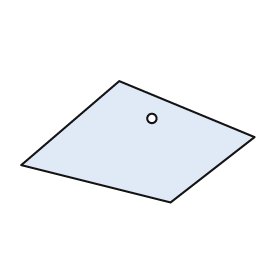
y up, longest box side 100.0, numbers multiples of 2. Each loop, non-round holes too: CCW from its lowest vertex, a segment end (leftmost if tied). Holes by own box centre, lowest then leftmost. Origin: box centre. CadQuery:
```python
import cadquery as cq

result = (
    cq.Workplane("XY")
    .moveTo(14.0, -26.0)
    .lineTo(50.0, 2.0)
    .lineTo(-8.0, 26.0)
    .lineTo(-50.0, -10.0)
    .close()
    .moveTo(6.0, 10.0)
    .circle(2.0)
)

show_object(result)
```